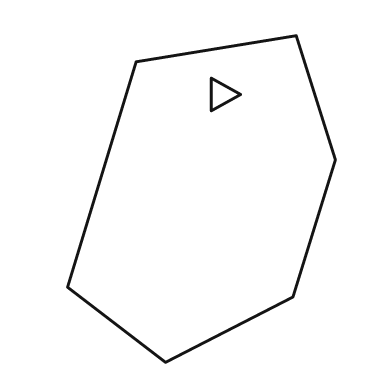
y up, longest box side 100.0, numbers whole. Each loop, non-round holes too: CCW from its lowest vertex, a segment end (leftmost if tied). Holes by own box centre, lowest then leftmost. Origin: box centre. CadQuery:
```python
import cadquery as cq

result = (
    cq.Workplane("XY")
    .moveTo(-11.0, -50.0)
    .lineTo(28.0, -30.0)
    .lineTo(41.0, 12.0)
    .lineTo(29.0, 50.0)
    .lineTo(-20.0, 42.0)
    .lineTo(-41.0, -27.0)
    .close()
    .moveTo(3.0, 27.0)
    .lineTo(12.0, 32.0)
    .lineTo(3.0, 37.0)
    .close()
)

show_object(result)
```